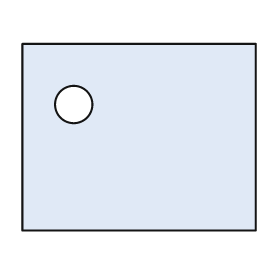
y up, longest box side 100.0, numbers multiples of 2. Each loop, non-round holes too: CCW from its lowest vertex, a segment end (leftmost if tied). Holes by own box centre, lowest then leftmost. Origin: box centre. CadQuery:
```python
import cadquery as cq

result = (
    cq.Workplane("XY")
    .moveTo(-50.0, -40.0)
    .lineTo(50.0, -40.0)
    .lineTo(50.0, 40.0)
    .lineTo(-50.0, 40.0)
    .close()
    .moveTo(-28.0, 14.0)
    .circle(8.0)
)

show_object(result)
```